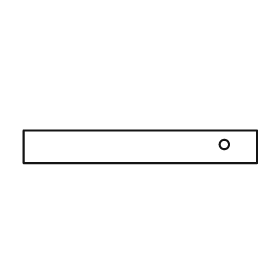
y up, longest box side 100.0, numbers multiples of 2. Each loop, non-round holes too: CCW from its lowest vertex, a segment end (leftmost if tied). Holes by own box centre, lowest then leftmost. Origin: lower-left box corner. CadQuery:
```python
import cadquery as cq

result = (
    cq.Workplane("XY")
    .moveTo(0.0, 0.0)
    .lineTo(100.0, 0.0)
    .lineTo(100.0, 14.0)
    .lineTo(0.0, 14.0)
    .close()
    .moveTo(86.0, 8.0)
    .circle(2.0)
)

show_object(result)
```